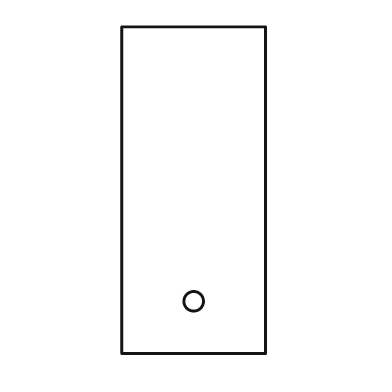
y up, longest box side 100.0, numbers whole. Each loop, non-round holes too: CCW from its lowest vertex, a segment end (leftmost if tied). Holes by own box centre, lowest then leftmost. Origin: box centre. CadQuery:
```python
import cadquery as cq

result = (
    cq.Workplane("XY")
    .moveTo(-22.0, -50.0)
    .lineTo(22.0, -50.0)
    .lineTo(22.0, 50.0)
    .lineTo(-22.0, 50.0)
    .close()
    .moveTo(0.0, -34.0)
    .circle(3.0)
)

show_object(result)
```